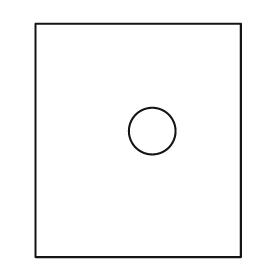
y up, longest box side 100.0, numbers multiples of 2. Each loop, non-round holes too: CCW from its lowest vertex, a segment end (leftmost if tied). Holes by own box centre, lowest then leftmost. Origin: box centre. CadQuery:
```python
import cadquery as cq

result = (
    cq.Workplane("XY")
    .moveTo(-44.0, -50.0)
    .lineTo(44.0, -50.0)
    .lineTo(44.0, 50.0)
    .lineTo(-44.0, 50.0)
    .close()
    .moveTo(6.0, 4.0)
    .circle(10.0)
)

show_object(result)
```